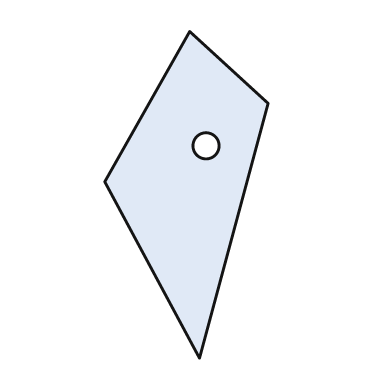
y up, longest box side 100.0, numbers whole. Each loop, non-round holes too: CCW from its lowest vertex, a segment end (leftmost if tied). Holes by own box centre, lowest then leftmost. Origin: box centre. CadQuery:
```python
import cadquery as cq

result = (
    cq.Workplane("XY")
    .moveTo(4.0, -50.0)
    .lineTo(25.0, 28.0)
    .lineTo(1.0, 50.0)
    .lineTo(-25.0, 4.0)
    .close()
    .moveTo(6.0, 15.0)
    .circle(4.0)
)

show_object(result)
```